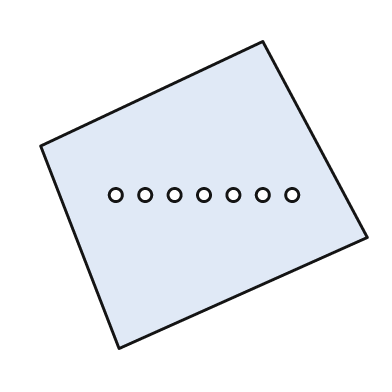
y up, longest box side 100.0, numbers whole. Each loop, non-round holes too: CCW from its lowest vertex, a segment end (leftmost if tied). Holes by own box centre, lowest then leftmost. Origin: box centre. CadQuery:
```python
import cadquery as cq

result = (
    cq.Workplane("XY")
    .moveTo(-26.0, -47.0)
    .lineTo(50.0, -13.0)
    .lineTo(18.0, 47.0)
    .lineTo(-50.0, 15.0)
    .close()
    .moveTo(-27.0, 0.0)
    .circle(2.0)
    .moveTo(-18.0, 0.0)
    .circle(2.0)
    .moveTo(-9.0, 0.0)
    .circle(2.0)
    .moveTo(0.0, 0.0)
    .circle(2.0)
    .moveTo(9.0, 0.0)
    .circle(2.0)
    .moveTo(18.0, 0.0)
    .circle(2.0)
    .moveTo(27.0, 0.0)
    .circle(2.0)
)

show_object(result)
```